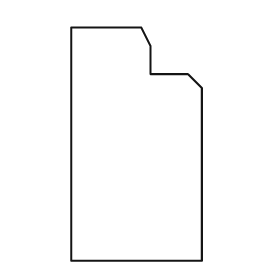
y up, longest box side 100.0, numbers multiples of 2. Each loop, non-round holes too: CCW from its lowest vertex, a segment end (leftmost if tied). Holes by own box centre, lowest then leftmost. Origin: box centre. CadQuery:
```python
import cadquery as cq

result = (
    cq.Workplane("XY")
    .moveTo(-28.0, -50.0)
    .lineTo(28.0, -50.0)
    .lineTo(28.0, 24.0)
    .lineTo(22.0, 30.0)
    .lineTo(6.0, 30.0)
    .lineTo(6.0, 42.0)
    .lineTo(2.0, 50.0)
    .lineTo(-28.0, 50.0)
    .close()
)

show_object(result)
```